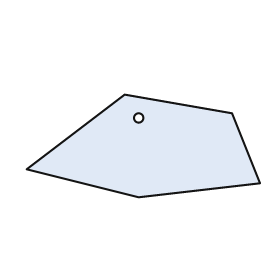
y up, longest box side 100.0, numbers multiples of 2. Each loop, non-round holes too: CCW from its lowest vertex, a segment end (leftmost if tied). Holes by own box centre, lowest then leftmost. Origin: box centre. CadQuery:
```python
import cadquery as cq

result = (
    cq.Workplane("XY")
    .moveTo(-2.0, -22.0)
    .lineTo(50.0, -16.0)
    .lineTo(38.0, 14.0)
    .lineTo(-8.0, 22.0)
    .lineTo(-50.0, -10.0)
    .close()
    .moveTo(-2.0, 12.0)
    .circle(2.0)
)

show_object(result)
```